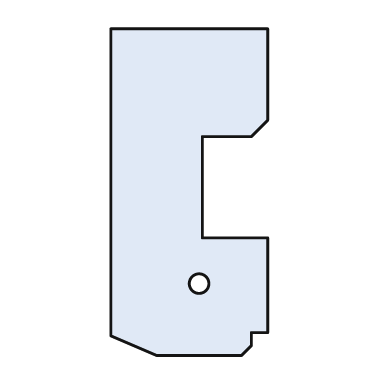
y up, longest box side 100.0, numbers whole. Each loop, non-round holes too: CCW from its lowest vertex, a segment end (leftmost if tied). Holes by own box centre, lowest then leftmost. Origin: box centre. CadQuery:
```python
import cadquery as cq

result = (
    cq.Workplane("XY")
    .moveTo(-10.0, -50.0)
    .lineTo(16.0, -50.0)
    .lineTo(19.0, -47.0)
    .lineTo(19.0, -43.0)
    .lineTo(24.0, -43.0)
    .lineTo(24.0, -14.0)
    .lineTo(4.0, -14.0)
    .lineTo(4.0, 17.0)
    .lineTo(19.0, 17.0)
    .lineTo(24.0, 22.0)
    .lineTo(24.0, 50.0)
    .lineTo(-24.0, 50.0)
    .lineTo(-24.0, -44.0)
    .close()
    .moveTo(3.0, -28.0)
    .circle(3.0)
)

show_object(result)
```